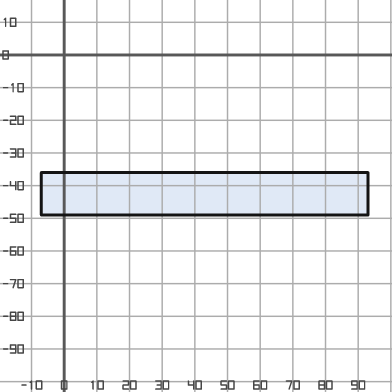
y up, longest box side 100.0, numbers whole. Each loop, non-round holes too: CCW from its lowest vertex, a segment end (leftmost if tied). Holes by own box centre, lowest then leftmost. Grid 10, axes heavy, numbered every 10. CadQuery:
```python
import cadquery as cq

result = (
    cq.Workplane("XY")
    .moveTo(-7.0, -49.0)
    .lineTo(93.0, -49.0)
    .lineTo(93.0, -36.0)
    .lineTo(-7.0, -36.0)
    .close()
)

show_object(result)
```